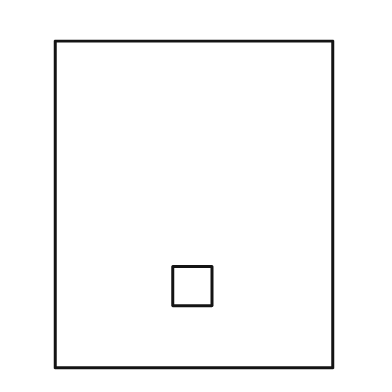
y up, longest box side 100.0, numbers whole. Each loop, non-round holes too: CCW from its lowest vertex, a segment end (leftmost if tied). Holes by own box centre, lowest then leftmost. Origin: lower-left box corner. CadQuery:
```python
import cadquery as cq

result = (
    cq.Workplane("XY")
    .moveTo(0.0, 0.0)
    .lineTo(85.0, 0.0)
    .lineTo(85.0, 100.0)
    .lineTo(0.0, 100.0)
    .close()
    .moveTo(36.0, 19.0)
    .lineTo(48.0, 19.0)
    .lineTo(48.0, 31.0)
    .lineTo(36.0, 31.0)
    .close()
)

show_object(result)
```